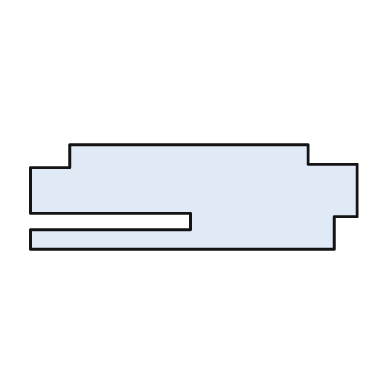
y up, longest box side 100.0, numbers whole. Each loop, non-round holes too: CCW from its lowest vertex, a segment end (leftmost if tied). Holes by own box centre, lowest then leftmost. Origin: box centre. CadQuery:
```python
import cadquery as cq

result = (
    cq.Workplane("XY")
    .moveTo(-50.0, -16.0)
    .lineTo(43.0, -16.0)
    .lineTo(43.0, -6.0)
    .lineTo(50.0, -6.0)
    .lineTo(50.0, 10.0)
    .lineTo(35.0, 10.0)
    .lineTo(35.0, 16.0)
    .lineTo(-38.0, 16.0)
    .lineTo(-38.0, 9.0)
    .lineTo(-50.0, 9.0)
    .lineTo(-50.0, -5.0)
    .lineTo(-1.0, -5.0)
    .lineTo(-1.0, -10.0)
    .lineTo(-50.0, -10.0)
    .close()
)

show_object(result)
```